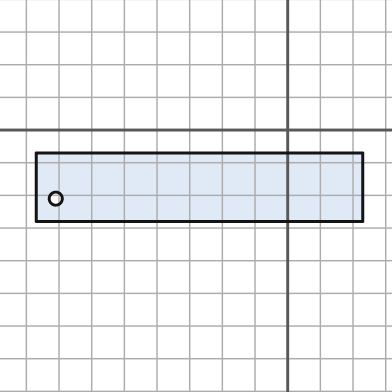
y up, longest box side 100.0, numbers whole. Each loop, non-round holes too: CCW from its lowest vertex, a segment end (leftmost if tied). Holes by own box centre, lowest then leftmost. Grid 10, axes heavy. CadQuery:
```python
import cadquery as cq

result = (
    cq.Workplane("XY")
    .moveTo(-77.0, -28.0)
    .lineTo(23.0, -28.0)
    .lineTo(23.0, -7.0)
    .lineTo(-77.0, -7.0)
    .close()
    .moveTo(-71.0, -21.0)
    .circle(2.0)
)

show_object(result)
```